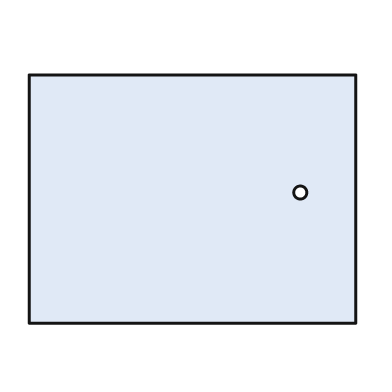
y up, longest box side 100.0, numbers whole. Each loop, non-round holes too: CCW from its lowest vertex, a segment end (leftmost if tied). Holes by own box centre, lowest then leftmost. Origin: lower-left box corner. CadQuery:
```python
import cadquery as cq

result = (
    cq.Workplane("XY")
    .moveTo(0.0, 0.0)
    .lineTo(100.0, 0.0)
    .lineTo(100.0, 76.0)
    .lineTo(0.0, 76.0)
    .close()
    .moveTo(83.0, 40.0)
    .circle(2.0)
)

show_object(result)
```